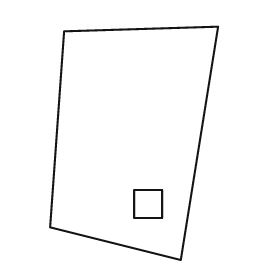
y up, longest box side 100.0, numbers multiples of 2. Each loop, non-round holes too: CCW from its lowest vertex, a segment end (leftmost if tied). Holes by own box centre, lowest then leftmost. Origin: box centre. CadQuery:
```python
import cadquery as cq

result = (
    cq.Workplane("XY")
    .moveTo(20.0, -50.0)
    .lineTo(36.0, 50.0)
    .lineTo(-30.0, 48.0)
    .lineTo(-36.0, -36.0)
    .close()
    .moveTo(0.0, -32.0)
    .lineTo(12.0, -32.0)
    .lineTo(12.0, -20.0)
    .lineTo(0.0, -20.0)
    .close()
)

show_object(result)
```